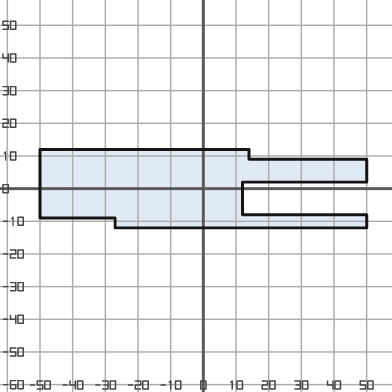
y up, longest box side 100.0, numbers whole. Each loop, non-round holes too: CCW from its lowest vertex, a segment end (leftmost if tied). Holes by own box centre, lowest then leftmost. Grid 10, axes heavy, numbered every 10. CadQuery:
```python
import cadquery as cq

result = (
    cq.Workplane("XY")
    .moveTo(-27.0, -12.0)
    .lineTo(50.0, -12.0)
    .lineTo(50.0, -8.0)
    .lineTo(12.0, -8.0)
    .lineTo(12.0, 2.0)
    .lineTo(50.0, 2.0)
    .lineTo(50.0, 9.0)
    .lineTo(14.0, 9.0)
    .lineTo(14.0, 12.0)
    .lineTo(-50.0, 12.0)
    .lineTo(-50.0, -9.0)
    .lineTo(-27.0, -9.0)
    .close()
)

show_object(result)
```